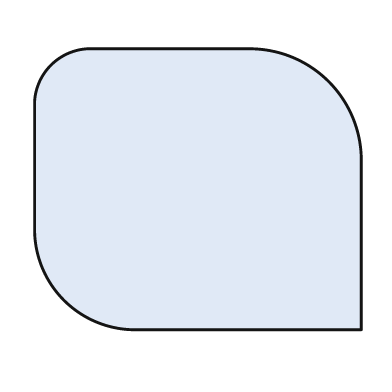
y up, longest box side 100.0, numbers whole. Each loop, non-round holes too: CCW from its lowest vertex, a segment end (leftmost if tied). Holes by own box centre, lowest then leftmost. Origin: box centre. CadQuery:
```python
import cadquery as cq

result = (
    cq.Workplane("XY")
    .moveTo(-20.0, -43.0)
    .lineTo(50.0, -43.0)
    .lineTo(50.0, 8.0)
    .threePointArc((40.0, 33.0), (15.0, 43.0))
    .lineTo(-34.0, 43.0)
    .threePointArc((-45.0, 38.0), (-50.0, 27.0))
    .lineTo(-50.0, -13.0)
    .threePointArc((-41.0, -34.0), (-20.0, -43.0))
    .close()
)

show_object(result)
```